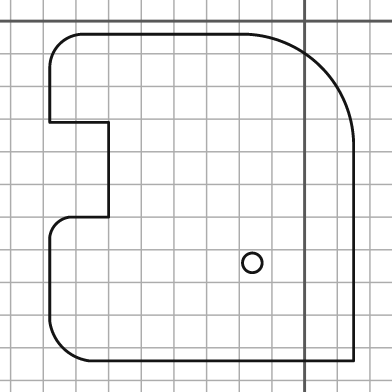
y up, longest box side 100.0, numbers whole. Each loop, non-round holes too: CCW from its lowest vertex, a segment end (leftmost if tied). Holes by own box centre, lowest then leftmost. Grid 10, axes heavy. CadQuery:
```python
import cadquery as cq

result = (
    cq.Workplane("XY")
    .moveTo(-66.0, -104.0)
    .lineTo(15.0, -104.0)
    .lineTo(15.0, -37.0)
    .threePointArc((5.0, -14.0), (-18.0, -4.0))
    .lineTo(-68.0, -4.0)
    .threePointArc((-75.0, -7.0), (-78.0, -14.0))
    .lineTo(-78.0, -31.0)
    .lineTo(-60.0, -31.0)
    .lineTo(-60.0, -60.0)
    .lineTo(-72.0, -60.0)
    .threePointArc((-76.0, -62.0), (-78.0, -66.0))
    .lineTo(-78.0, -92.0)
    .threePointArc((-74.0, -100.0), (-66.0, -104.0))
    .close()
    .moveTo(-16.0, -74.0)
    .circle(3.0)
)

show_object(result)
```